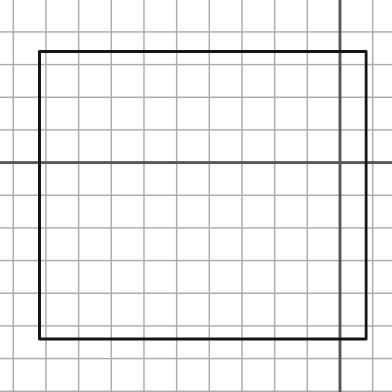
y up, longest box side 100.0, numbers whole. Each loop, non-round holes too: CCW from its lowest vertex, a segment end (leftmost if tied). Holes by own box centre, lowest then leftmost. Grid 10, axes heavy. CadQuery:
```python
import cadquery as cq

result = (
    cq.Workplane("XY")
    .moveTo(-92.0, -54.0)
    .lineTo(8.0, -54.0)
    .lineTo(8.0, 34.0)
    .lineTo(-92.0, 34.0)
    .close()
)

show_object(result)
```